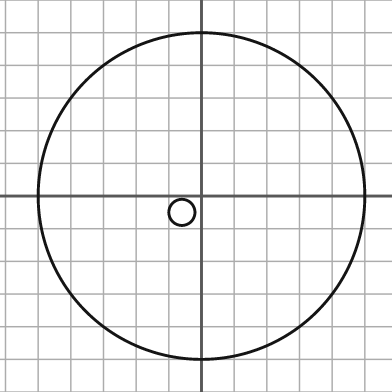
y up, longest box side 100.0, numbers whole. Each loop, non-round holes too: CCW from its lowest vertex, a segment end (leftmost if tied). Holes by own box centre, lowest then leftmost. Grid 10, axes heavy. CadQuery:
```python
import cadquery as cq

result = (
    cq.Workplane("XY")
    .moveTo(0.0, 0.0)
    .circle(50.0)
    .moveTo(-6.0, -5.0)
    .circle(4.0)
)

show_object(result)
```